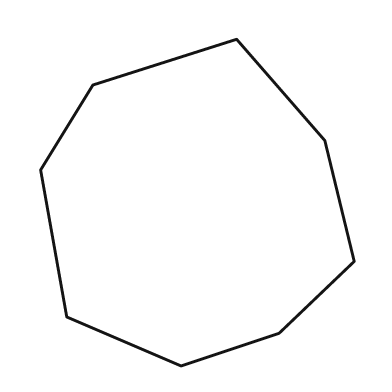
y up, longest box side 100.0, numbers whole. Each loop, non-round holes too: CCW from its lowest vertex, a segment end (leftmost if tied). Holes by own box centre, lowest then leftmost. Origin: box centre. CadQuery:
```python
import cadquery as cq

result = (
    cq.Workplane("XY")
    .moveTo(-5.0, -50.0)
    .lineTo(25.0, -40.0)
    .lineTo(48.0, -18.0)
    .lineTo(39.0, 19.0)
    .lineTo(12.0, 50.0)
    .lineTo(-32.0, 36.0)
    .lineTo(-48.0, 10.0)
    .lineTo(-40.0, -35.0)
    .close()
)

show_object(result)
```